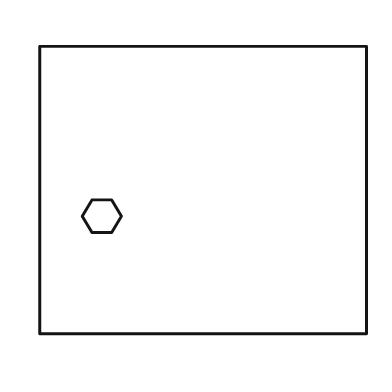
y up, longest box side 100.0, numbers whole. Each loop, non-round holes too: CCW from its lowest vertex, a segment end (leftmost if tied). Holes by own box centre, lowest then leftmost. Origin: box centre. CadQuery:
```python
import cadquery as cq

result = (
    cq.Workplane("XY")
    .moveTo(-50.0, -44.0)
    .lineTo(50.0, -44.0)
    .lineTo(50.0, 44.0)
    .lineTo(-50.0, 44.0)
    .close()
    .moveTo(-34.0, -13.0)
    .lineTo(-28.0, -13.0)
    .lineTo(-25.0, -8.0)
    .lineTo(-28.0, -3.0)
    .lineTo(-34.0, -3.0)
    .lineTo(-37.0, -8.0)
    .close()
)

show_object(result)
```